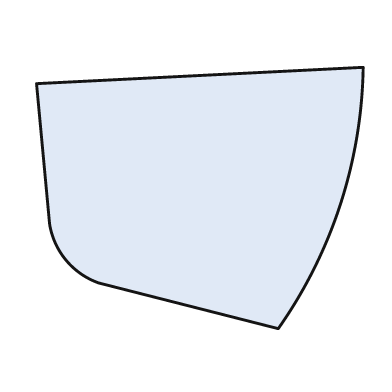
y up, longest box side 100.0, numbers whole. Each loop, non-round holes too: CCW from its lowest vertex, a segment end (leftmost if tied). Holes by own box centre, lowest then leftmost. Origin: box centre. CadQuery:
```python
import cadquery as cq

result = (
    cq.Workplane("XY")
    .moveTo(24.0, -40.0)
    .threePointArc((43.0, -2.0), (50.0, 40.0))
    .lineTo(-50.0, 35.0)
    .lineTo(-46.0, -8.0)
    .threePointArc((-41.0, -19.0), (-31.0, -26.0))
    .close()
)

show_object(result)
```